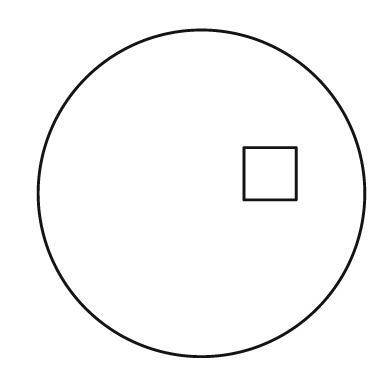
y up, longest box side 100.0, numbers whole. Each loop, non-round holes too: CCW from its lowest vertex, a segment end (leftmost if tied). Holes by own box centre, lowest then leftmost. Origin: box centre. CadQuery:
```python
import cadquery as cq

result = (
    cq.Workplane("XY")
    .moveTo(0.0, 0.0)
    .circle(50.0)
    .moveTo(13.0, -2.0)
    .lineTo(29.0, -2.0)
    .lineTo(29.0, 14.0)
    .lineTo(13.0, 14.0)
    .close()
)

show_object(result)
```